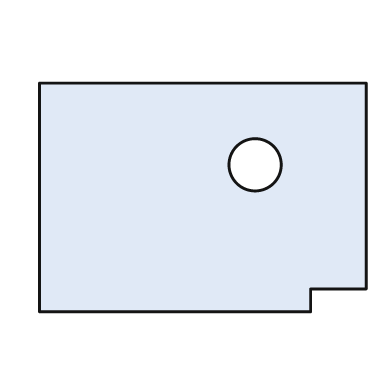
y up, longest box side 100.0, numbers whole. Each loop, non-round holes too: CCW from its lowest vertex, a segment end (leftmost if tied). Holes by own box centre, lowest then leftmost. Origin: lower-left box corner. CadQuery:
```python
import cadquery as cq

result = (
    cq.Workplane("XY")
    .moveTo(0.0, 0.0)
    .lineTo(83.0, 0.0)
    .lineTo(83.0, 7.0)
    .lineTo(100.0, 7.0)
    .lineTo(100.0, 70.0)
    .lineTo(0.0, 70.0)
    .close()
    .moveTo(66.0, 45.0)
    .circle(8.0)
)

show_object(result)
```